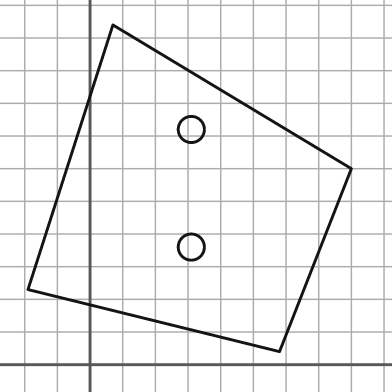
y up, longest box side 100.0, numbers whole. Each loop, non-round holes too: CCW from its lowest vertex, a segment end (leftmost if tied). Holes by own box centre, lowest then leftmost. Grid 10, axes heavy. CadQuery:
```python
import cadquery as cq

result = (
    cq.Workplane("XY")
    .moveTo(58.0, 4.0)
    .lineTo(80.0, 60.0)
    .lineTo(7.0, 104.0)
    .lineTo(-19.0, 23.0)
    .close()
    .moveTo(31.0, 36.0)
    .circle(4.0)
    .moveTo(31.0, 72.0)
    .circle(4.0)
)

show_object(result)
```